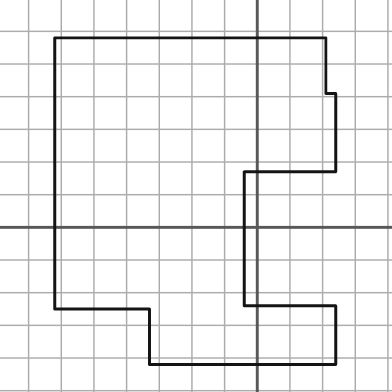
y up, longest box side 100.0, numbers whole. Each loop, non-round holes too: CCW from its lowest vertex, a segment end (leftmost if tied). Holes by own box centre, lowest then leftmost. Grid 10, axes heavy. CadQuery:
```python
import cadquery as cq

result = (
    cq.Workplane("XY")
    .moveTo(-33.0, -42.0)
    .lineTo(24.0, -42.0)
    .lineTo(24.0, -24.0)
    .lineTo(-4.0, -24.0)
    .lineTo(-4.0, 17.0)
    .lineTo(24.0, 17.0)
    .lineTo(24.0, 41.0)
    .lineTo(21.0, 41.0)
    .lineTo(21.0, 58.0)
    .lineTo(-62.0, 58.0)
    .lineTo(-62.0, -25.0)
    .lineTo(-33.0, -25.0)
    .close()
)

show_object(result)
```